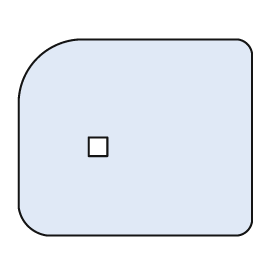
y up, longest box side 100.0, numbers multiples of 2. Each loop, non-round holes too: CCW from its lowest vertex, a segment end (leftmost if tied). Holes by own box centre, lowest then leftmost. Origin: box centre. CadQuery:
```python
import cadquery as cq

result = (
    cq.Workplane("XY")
    .moveTo(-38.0, -42.0)
    .lineTo(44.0, -42.0)
    .threePointArc((48.0, -40.0), (50.0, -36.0))
    .lineTo(50.0, 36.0)
    .threePointArc((48.0, 40.0), (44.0, 42.0))
    .lineTo(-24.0, 42.0)
    .threePointArc((-42.0, 34.0), (-50.0, 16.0))
    .lineTo(-50.0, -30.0)
    .threePointArc((-46.0, -38.0), (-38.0, -42.0))
    .close()
    .moveTo(-20.0, -8.0)
    .lineTo(-12.0, -8.0)
    .lineTo(-12.0, 0.0)
    .lineTo(-20.0, 0.0)
    .close()
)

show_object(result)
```